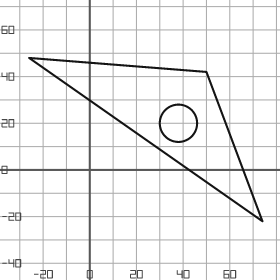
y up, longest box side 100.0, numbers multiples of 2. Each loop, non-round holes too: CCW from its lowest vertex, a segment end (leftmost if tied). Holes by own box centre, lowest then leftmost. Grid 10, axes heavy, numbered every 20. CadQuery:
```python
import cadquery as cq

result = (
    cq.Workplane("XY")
    .moveTo(74.0, -22.0)
    .lineTo(50.0, 42.0)
    .lineTo(-26.0, 48.0)
    .close()
    .moveTo(38.0, 20.0)
    .circle(8.0)
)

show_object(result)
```